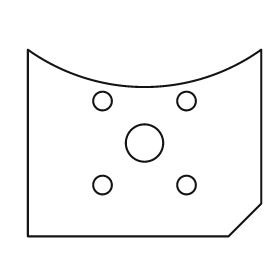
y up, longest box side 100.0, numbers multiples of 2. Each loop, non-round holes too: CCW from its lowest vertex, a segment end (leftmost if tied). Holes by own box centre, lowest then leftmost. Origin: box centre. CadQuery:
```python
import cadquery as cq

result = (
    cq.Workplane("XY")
    .moveTo(-50.0, -40.0)
    .lineTo(36.0, -40.0)
    .lineTo(50.0, -26.0)
    .lineTo(50.0, 40.0)
    .threePointArc((0.0, 24.0), (-50.0, 40.0))
    .close()
    .moveTo(-18.0, -18.0)
    .circle(4.0)
    .moveTo(18.0, -18.0)
    .circle(4.0)
    .moveTo(0.0, 0.0)
    .circle(8.0)
    .moveTo(-18.0, 18.0)
    .circle(4.0)
    .moveTo(18.0, 18.0)
    .circle(4.0)
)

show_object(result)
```